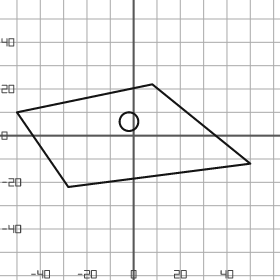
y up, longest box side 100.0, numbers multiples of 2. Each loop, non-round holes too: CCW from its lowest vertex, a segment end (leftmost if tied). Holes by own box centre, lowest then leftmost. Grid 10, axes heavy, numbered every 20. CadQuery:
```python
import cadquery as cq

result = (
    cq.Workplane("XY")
    .moveTo(-28.0, -22.0)
    .lineTo(50.0, -12.0)
    .lineTo(8.0, 22.0)
    .lineTo(-50.0, 10.0)
    .close()
    .moveTo(-2.0, 6.0)
    .circle(4.0)
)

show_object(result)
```